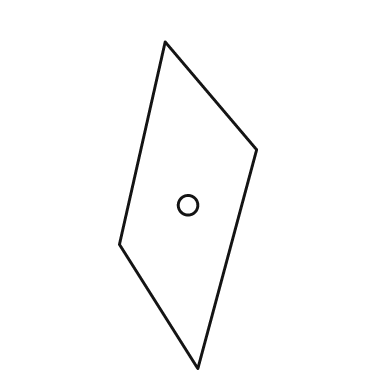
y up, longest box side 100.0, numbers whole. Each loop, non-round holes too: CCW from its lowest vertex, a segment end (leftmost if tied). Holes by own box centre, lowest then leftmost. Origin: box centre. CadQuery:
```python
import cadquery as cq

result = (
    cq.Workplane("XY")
    .moveTo(3.0, -50.0)
    .lineTo(21.0, 17.0)
    .lineTo(-7.0, 50.0)
    .lineTo(-21.0, -12.0)
    .close()
    .moveTo(0.0, 0.0)
    .circle(3.0)
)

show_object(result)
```